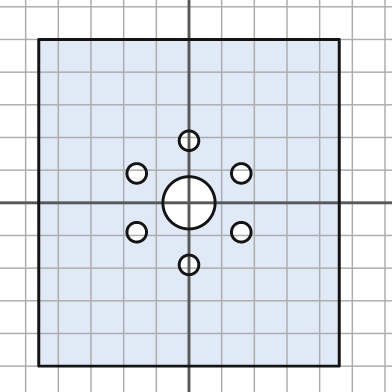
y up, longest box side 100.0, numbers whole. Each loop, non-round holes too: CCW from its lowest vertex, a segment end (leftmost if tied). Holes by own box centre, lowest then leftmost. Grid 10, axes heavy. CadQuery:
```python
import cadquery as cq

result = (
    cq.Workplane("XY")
    .moveTo(-46.0, -50.0)
    .lineTo(46.0, -50.0)
    .lineTo(46.0, 50.0)
    .lineTo(-46.0, 50.0)
    .close()
    .moveTo(0.0, -19.0)
    .circle(3.0)
    .moveTo(-16.0, -9.0)
    .circle(3.0)
    .moveTo(16.0, -9.0)
    .circle(3.0)
    .moveTo(0.0, 0.0)
    .circle(8.0)
    .moveTo(-16.0, 9.0)
    .circle(3.0)
    .moveTo(16.0, 9.0)
    .circle(3.0)
    .moveTo(0.0, 19.0)
    .circle(3.0)
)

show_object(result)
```